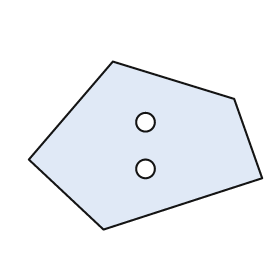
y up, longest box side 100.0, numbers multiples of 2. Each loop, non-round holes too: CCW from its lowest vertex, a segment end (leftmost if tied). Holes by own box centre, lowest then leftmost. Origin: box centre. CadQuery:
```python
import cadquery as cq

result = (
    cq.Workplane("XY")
    .moveTo(-18.0, -36.0)
    .lineTo(50.0, -14.0)
    .lineTo(38.0, 20.0)
    .lineTo(-14.0, 36.0)
    .lineTo(-50.0, -6.0)
    .close()
    .moveTo(0.0, -10.0)
    .circle(4.0)
    .moveTo(0.0, 10.0)
    .circle(4.0)
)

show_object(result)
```